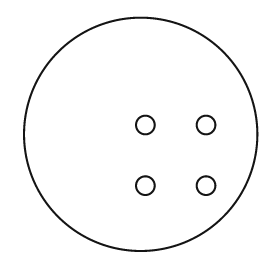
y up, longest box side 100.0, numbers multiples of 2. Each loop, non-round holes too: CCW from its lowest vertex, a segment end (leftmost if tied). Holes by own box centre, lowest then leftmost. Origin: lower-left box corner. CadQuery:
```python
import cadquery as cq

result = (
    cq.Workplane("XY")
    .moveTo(50.0, 50.0)
    .circle(50.0)
    .moveTo(52.0, 28.0)
    .circle(4.0)
    .moveTo(78.0, 28.0)
    .circle(4.0)
    .moveTo(52.0, 54.0)
    .circle(4.0)
    .moveTo(78.0, 54.0)
    .circle(4.0)
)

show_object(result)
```